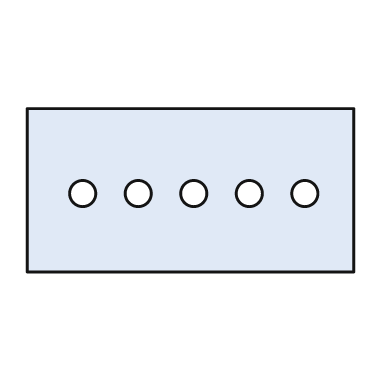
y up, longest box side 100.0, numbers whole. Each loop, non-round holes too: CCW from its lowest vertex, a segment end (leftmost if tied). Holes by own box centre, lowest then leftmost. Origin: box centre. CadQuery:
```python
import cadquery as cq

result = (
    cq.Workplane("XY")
    .moveTo(-50.0, -25.0)
    .lineTo(50.0, -25.0)
    .lineTo(50.0, 25.0)
    .lineTo(-50.0, 25.0)
    .close()
    .moveTo(-33.0, -1.0)
    .circle(4.0)
    .moveTo(-16.0, -1.0)
    .circle(4.0)
    .moveTo(1.0, -1.0)
    .circle(4.0)
    .moveTo(18.0, -1.0)
    .circle(4.0)
    .moveTo(35.0, -1.0)
    .circle(4.0)
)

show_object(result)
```